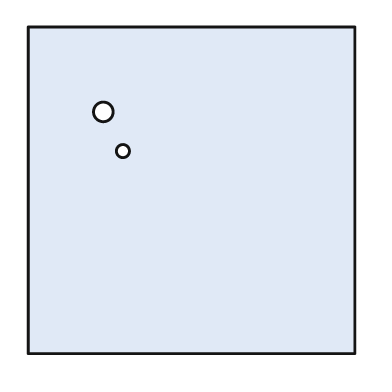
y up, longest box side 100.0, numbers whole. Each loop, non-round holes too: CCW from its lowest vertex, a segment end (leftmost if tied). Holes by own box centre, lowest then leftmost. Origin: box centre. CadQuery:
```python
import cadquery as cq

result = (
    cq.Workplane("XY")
    .moveTo(-50.0, -50.0)
    .lineTo(50.0, -50.0)
    .lineTo(50.0, 50.0)
    .lineTo(-50.0, 50.0)
    .close()
    .moveTo(-21.0, 12.0)
    .circle(2.0)
    .moveTo(-27.0, 24.0)
    .circle(3.0)
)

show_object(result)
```